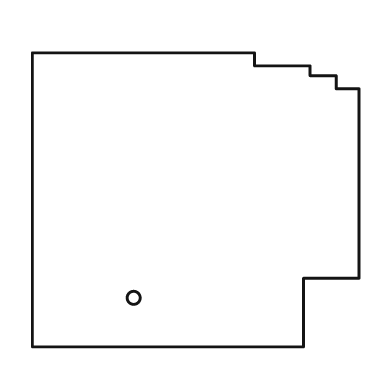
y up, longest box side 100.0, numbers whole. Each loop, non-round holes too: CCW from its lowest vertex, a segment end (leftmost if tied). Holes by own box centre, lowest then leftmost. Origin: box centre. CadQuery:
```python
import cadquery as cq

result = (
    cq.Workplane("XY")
    .moveTo(-50.0, -45.0)
    .lineTo(33.0, -45.0)
    .lineTo(33.0, -24.0)
    .lineTo(50.0, -24.0)
    .lineTo(50.0, 34.0)
    .lineTo(43.0, 34.0)
    .lineTo(43.0, 38.0)
    .lineTo(35.0, 38.0)
    .lineTo(35.0, 41.0)
    .lineTo(18.0, 41.0)
    .lineTo(18.0, 45.0)
    .lineTo(-50.0, 45.0)
    .close()
    .moveTo(-19.0, -30.0)
    .circle(2.0)
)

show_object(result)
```